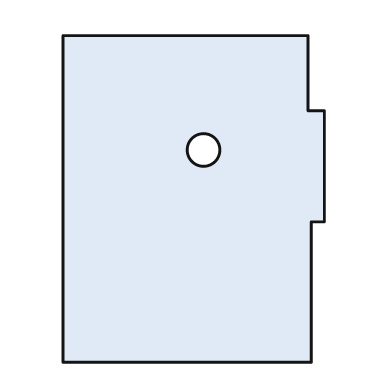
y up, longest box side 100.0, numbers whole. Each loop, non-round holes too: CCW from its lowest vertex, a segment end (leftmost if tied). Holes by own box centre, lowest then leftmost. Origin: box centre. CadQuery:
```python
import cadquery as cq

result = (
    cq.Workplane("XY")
    .moveTo(-40.0, -50.0)
    .lineTo(36.0, -50.0)
    .lineTo(36.0, -7.0)
    .lineTo(40.0, -7.0)
    .lineTo(40.0, 27.0)
    .lineTo(35.0, 27.0)
    .lineTo(35.0, 50.0)
    .lineTo(-40.0, 50.0)
    .close()
    .moveTo(3.0, 15.0)
    .circle(5.0)
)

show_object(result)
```